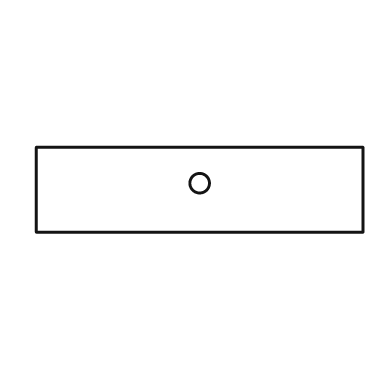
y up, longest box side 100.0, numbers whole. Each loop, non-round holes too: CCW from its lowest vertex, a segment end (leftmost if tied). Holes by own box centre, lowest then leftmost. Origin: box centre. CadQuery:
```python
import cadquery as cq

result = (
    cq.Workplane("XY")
    .moveTo(-50.0, -13.0)
    .lineTo(50.0, -13.0)
    .lineTo(50.0, 13.0)
    .lineTo(-50.0, 13.0)
    .close()
    .moveTo(0.0, 2.0)
    .circle(3.0)
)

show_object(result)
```